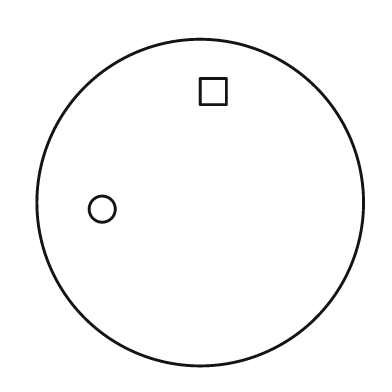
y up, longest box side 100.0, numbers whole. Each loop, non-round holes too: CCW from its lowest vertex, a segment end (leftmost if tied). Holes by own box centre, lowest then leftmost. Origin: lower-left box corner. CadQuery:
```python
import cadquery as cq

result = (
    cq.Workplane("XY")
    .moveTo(50.0, 50.0)
    .circle(50.0)
    .moveTo(20.0, 48.0)
    .circle(4.0)
    .moveTo(50.0, 80.0)
    .lineTo(58.0, 80.0)
    .lineTo(58.0, 88.0)
    .lineTo(50.0, 88.0)
    .close()
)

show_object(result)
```